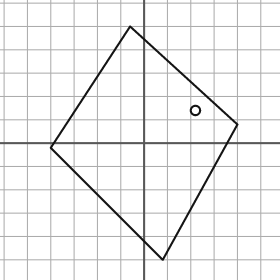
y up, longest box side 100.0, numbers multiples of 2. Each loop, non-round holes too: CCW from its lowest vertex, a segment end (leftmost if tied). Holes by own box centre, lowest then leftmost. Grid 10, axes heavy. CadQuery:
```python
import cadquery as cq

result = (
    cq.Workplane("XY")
    .moveTo(8.0, -50.0)
    .lineTo(40.0, 8.0)
    .lineTo(-6.0, 50.0)
    .lineTo(-40.0, -2.0)
    .close()
    .moveTo(22.0, 14.0)
    .circle(2.0)
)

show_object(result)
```